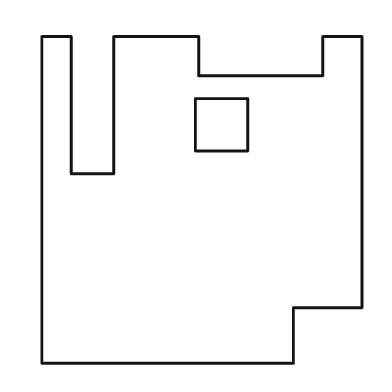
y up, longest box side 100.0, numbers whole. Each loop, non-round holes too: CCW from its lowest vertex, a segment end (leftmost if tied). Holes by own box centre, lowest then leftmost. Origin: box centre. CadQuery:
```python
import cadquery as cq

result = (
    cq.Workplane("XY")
    .moveTo(-49.0, -50.0)
    .lineTo(28.0, -50.0)
    .lineTo(28.0, -33.0)
    .lineTo(49.0, -33.0)
    .lineTo(49.0, 50.0)
    .lineTo(37.0, 50.0)
    .lineTo(37.0, 38.0)
    .lineTo(-1.0, 38.0)
    .lineTo(-1.0, 50.0)
    .lineTo(-27.0, 50.0)
    .lineTo(-27.0, 8.0)
    .lineTo(-40.0, 8.0)
    .lineTo(-40.0, 50.0)
    .lineTo(-49.0, 50.0)
    .close()
    .moveTo(-2.0, 15.0)
    .lineTo(14.0, 15.0)
    .lineTo(14.0, 31.0)
    .lineTo(-2.0, 31.0)
    .close()
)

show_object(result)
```